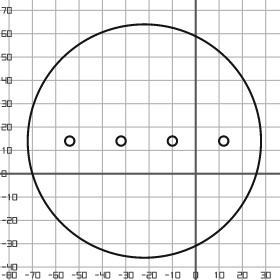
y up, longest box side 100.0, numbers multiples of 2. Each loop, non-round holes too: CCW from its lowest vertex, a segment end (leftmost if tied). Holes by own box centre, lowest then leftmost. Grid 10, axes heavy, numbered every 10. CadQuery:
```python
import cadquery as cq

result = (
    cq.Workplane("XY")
    .moveTo(-22.0, 14.0)
    .circle(50.0)
    .moveTo(-54.0, 14.0)
    .circle(2.0)
    .moveTo(-32.0, 14.0)
    .circle(2.0)
    .moveTo(-10.0, 14.0)
    .circle(2.0)
    .moveTo(12.0, 14.0)
    .circle(2.0)
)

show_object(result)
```